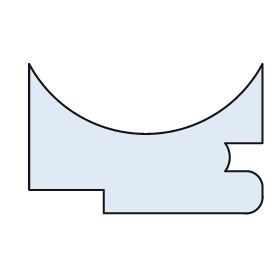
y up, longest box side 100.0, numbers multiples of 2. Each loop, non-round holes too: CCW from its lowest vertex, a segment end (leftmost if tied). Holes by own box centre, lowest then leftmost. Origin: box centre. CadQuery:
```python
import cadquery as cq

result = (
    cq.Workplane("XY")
    .moveTo(-18.0, -32.0)
    .lineTo(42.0, -32.0)
    .threePointArc((48.0, -30.0), (50.0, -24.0))
    .lineTo(50.0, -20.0)
    .threePointArc((48.0, -16.0), (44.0, -14.0))
    .lineTo(34.0, -14.0)
    .threePointArc((36.0, -8.0), (34.0, -2.0))
    .lineTo(50.0, -2.0)
    .lineTo(50.0, 32.0)
    .threePointArc((0.0, 2.0), (-50.0, 32.0))
    .lineTo(-50.0, -22.0)
    .lineTo(-18.0, -22.0)
    .close()
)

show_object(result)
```